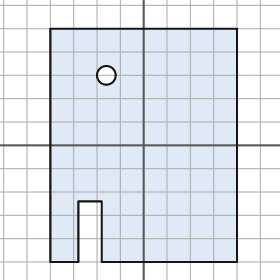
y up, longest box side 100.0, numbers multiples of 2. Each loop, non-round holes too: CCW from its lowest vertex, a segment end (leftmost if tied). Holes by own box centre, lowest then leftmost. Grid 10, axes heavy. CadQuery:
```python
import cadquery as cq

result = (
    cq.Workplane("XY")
    .moveTo(-40.0, -50.0)
    .lineTo(-28.0, -50.0)
    .lineTo(-28.0, -24.0)
    .lineTo(-18.0, -24.0)
    .lineTo(-18.0, -50.0)
    .lineTo(40.0, -50.0)
    .lineTo(40.0, 50.0)
    .lineTo(-40.0, 50.0)
    .close()
    .moveTo(-16.0, 30.0)
    .circle(4.0)
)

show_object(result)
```